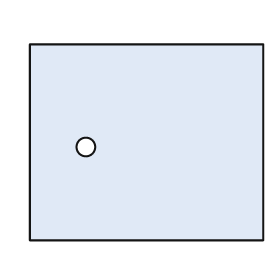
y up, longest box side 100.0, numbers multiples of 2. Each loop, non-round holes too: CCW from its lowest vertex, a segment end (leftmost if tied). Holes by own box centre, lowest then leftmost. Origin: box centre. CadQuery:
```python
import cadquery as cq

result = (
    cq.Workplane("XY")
    .moveTo(-50.0, -42.0)
    .lineTo(50.0, -42.0)
    .lineTo(50.0, 42.0)
    .lineTo(-50.0, 42.0)
    .close()
    .moveTo(-26.0, -2.0)
    .circle(4.0)
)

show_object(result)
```